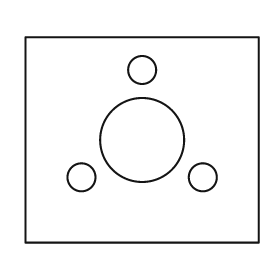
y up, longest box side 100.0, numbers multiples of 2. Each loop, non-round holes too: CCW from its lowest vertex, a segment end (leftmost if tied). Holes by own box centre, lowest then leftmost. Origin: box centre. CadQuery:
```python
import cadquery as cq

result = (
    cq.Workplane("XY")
    .moveTo(-50.0, -44.0)
    .lineTo(50.0, -44.0)
    .lineTo(50.0, 44.0)
    .lineTo(-50.0, 44.0)
    .close()
    .moveTo(-26.0, -16.0)
    .circle(6.0)
    .moveTo(26.0, -16.0)
    .circle(6.0)
    .moveTo(0.0, 0.0)
    .circle(18.0)
    .moveTo(0.0, 30.0)
    .circle(6.0)
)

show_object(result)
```